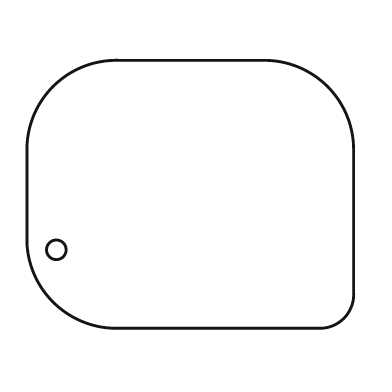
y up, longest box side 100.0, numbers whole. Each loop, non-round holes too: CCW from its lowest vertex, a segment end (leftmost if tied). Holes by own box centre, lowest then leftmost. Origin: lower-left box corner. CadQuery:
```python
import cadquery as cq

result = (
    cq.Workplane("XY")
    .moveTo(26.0, 0.0)
    .lineTo(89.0, 0.0)
    .threePointArc((97.0, 3.0), (100.0, 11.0))
    .lineTo(100.0, 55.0)
    .threePointArc((92.0, 74.0), (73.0, 82.0))
    .lineTo(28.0, 82.0)
    .threePointArc((8.0, 74.0), (0.0, 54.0))
    .lineTo(0.0, 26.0)
    .threePointArc((8.0, 8.0), (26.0, 0.0))
    .close()
    .moveTo(9.0, 24.0)
    .circle(3.0)
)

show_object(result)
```